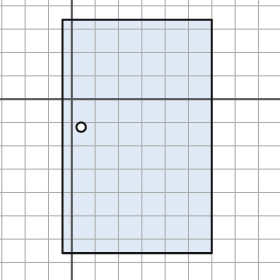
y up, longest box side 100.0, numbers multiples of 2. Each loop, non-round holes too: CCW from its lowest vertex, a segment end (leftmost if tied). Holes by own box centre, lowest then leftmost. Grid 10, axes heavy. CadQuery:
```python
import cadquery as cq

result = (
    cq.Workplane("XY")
    .moveTo(-4.0, -66.0)
    .lineTo(60.0, -66.0)
    .lineTo(60.0, 34.0)
    .lineTo(-4.0, 34.0)
    .close()
    .moveTo(4.0, -12.0)
    .circle(2.0)
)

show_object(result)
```